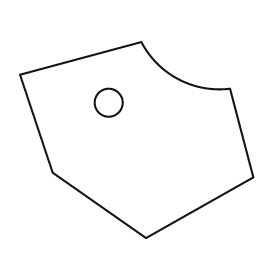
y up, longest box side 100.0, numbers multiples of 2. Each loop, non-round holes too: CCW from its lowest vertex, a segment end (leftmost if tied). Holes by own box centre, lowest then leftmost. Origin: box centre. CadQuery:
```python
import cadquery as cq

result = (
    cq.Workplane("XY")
    .moveTo(4.0, -42.0)
    .lineTo(50.0, -16.0)
    .lineTo(40.0, 22.0)
    .threePointArc((18.0, 26.0), (2.0, 42.0))
    .lineTo(-50.0, 28.0)
    .lineTo(-36.0, -14.0)
    .close()
    .moveTo(-12.0, 16.0)
    .circle(6.0)
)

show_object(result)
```